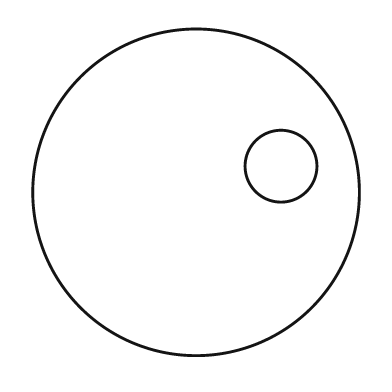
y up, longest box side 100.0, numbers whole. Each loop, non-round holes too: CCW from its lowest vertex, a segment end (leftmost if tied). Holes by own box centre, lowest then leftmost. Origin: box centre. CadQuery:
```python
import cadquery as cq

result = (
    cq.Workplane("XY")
    .moveTo(0.0, 0.0)
    .circle(50.0)
    .moveTo(26.0, 8.0)
    .circle(11.0)
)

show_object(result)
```